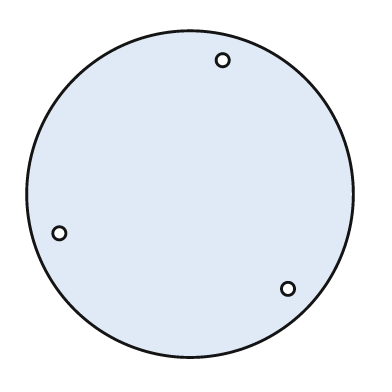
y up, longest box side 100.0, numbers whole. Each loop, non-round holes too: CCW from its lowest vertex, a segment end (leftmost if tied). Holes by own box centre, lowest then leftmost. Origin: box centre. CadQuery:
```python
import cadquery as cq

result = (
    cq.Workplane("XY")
    .moveTo(0.0, 0.0)
    .circle(50.0)
    .moveTo(30.0, -29.0)
    .circle(2.0)
    .moveTo(-40.0, -12.0)
    .circle(2.0)
    .moveTo(10.0, 41.0)
    .circle(2.0)
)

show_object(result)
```